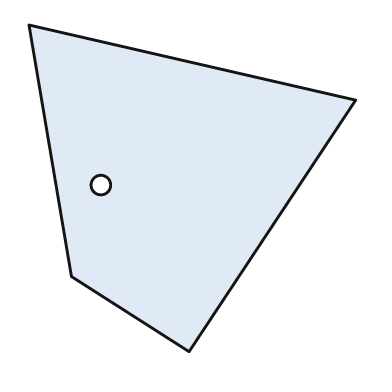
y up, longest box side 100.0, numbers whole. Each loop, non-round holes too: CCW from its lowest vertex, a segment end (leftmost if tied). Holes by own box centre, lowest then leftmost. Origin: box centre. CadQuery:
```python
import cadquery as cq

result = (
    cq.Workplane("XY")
    .moveTo(-1.0, -50.0)
    .lineTo(50.0, 27.0)
    .lineTo(-50.0, 50.0)
    .lineTo(-37.0, -27.0)
    .close()
    .moveTo(-28.0, 1.0)
    .circle(3.0)
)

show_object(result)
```